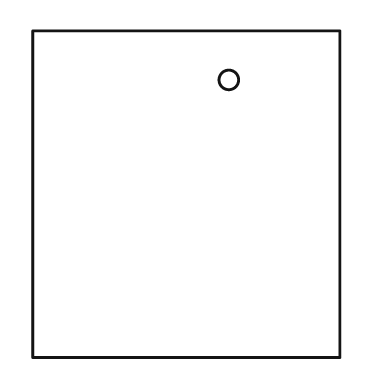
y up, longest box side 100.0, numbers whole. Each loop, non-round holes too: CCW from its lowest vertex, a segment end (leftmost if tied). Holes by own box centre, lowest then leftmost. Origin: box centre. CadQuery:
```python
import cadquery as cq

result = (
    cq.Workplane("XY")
    .moveTo(-47.0, -50.0)
    .lineTo(47.0, -50.0)
    .lineTo(47.0, 50.0)
    .lineTo(-47.0, 50.0)
    .close()
    .moveTo(13.0, 35.0)
    .circle(3.0)
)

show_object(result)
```